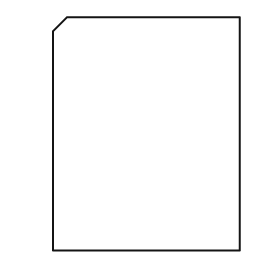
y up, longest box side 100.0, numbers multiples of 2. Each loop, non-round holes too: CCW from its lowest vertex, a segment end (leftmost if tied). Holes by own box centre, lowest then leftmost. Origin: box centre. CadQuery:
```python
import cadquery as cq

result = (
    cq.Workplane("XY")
    .moveTo(-40.0, -50.0)
    .lineTo(40.0, -50.0)
    .lineTo(40.0, 50.0)
    .lineTo(-34.0, 50.0)
    .lineTo(-40.0, 44.0)
    .close()
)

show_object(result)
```